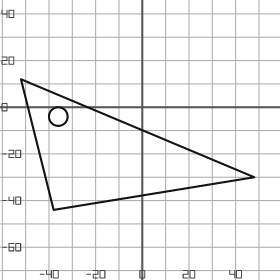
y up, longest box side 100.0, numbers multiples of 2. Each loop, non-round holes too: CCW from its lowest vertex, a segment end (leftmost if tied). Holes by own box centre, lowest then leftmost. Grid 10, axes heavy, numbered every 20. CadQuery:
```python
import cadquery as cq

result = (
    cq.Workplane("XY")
    .moveTo(-38.0, -44.0)
    .lineTo(48.0, -30.0)
    .lineTo(-52.0, 12.0)
    .close()
    .moveTo(-36.0, -4.0)
    .circle(4.0)
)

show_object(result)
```